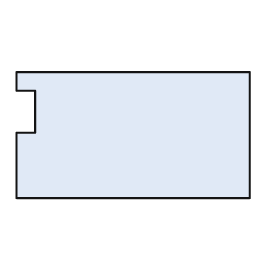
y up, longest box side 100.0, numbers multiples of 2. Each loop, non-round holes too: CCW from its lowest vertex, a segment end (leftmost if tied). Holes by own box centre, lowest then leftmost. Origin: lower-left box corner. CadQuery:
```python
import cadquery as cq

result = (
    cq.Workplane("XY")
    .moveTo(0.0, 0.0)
    .lineTo(100.0, 0.0)
    .lineTo(100.0, 54.0)
    .lineTo(0.0, 54.0)
    .lineTo(0.0, 46.0)
    .lineTo(8.0, 46.0)
    .lineTo(8.0, 28.0)
    .lineTo(0.0, 28.0)
    .close()
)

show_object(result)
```